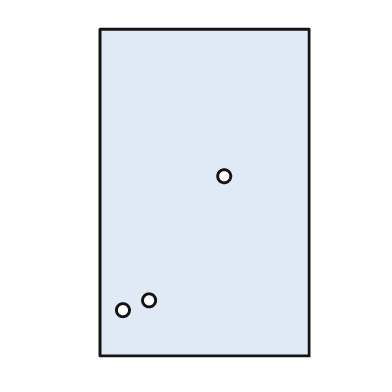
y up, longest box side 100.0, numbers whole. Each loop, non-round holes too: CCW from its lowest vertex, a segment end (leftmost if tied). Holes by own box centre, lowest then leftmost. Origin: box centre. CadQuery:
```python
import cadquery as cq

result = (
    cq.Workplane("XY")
    .moveTo(-32.0, -50.0)
    .lineTo(32.0, -50.0)
    .lineTo(32.0, 50.0)
    .lineTo(-32.0, 50.0)
    .close()
    .moveTo(-25.0, -36.0)
    .circle(2.0)
    .moveTo(-17.0, -33.0)
    .circle(2.0)
    .moveTo(6.0, 5.0)
    .circle(2.0)
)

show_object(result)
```